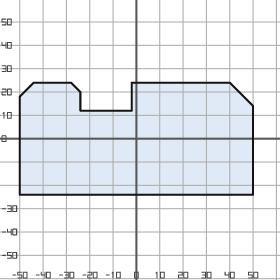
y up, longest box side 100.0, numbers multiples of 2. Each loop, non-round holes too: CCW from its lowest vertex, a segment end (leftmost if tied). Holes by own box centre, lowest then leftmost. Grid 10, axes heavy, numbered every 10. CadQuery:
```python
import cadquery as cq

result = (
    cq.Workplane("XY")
    .moveTo(-50.0, -24.0)
    .lineTo(50.0, -24.0)
    .lineTo(50.0, 14.0)
    .lineTo(40.0, 24.0)
    .lineTo(-2.0, 24.0)
    .lineTo(-2.0, 12.0)
    .lineTo(-24.0, 12.0)
    .lineTo(-24.0, 20.0)
    .lineTo(-28.0, 24.0)
    .lineTo(-44.0, 24.0)
    .lineTo(-50.0, 18.0)
    .close()
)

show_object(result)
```